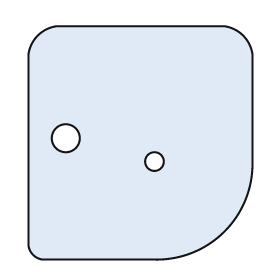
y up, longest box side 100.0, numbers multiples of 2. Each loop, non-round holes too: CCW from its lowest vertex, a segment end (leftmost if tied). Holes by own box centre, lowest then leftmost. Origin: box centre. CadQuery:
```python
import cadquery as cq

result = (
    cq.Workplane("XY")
    .moveTo(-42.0, -50.0)
    .lineTo(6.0, -50.0)
    .threePointArc((36.0, -38.0), (48.0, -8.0))
    .lineTo(48.0, 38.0)
    .threePointArc((44.0, 46.0), (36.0, 50.0))
    .lineTo(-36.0, 50.0)
    .threePointArc((-44.0, 46.0), (-48.0, 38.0))
    .lineTo(-48.0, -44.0)
    .threePointArc((-46.0, -48.0), (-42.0, -50.0))
    .close()
    .moveTo(6.0, -8.0)
    .circle(4.0)
    .moveTo(-32.0, 2.0)
    .circle(6.0)
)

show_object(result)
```